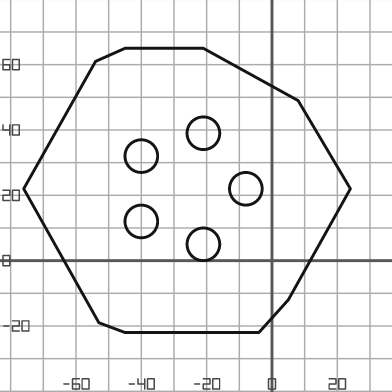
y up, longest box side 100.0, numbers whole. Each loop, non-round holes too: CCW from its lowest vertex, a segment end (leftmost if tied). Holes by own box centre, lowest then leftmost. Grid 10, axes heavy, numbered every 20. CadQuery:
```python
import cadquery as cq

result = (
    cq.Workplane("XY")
    .moveTo(-45.0, -22.0)
    .lineTo(-4.0, -22.0)
    .lineTo(5.0, -12.0)
    .lineTo(24.0, 22.0)
    .lineTo(8.0, 49.0)
    .lineTo(-21.0, 65.0)
    .lineTo(-45.0, 65.0)
    .lineTo(-54.0, 61.0)
    .lineTo(-76.0, 22.0)
    .lineTo(-53.0, -19.0)
    .close()
    .moveTo(-21.0, 5.0)
    .circle(5.0)
    .moveTo(-40.0, 12.0)
    .circle(5.0)
    .moveTo(-8.0, 22.0)
    .circle(5.0)
    .moveTo(-40.0, 32.0)
    .circle(5.0)
    .moveTo(-21.0, 39.0)
    .circle(5.0)
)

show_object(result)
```